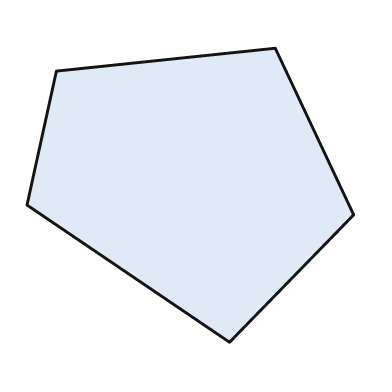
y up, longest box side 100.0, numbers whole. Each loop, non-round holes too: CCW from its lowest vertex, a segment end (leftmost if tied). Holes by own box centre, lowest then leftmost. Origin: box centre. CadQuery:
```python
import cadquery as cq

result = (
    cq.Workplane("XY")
    .moveTo(12.0, -45.0)
    .lineTo(50.0, -6.0)
    .lineTo(26.0, 45.0)
    .lineTo(-41.0, 38.0)
    .lineTo(-50.0, -3.0)
    .close()
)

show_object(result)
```